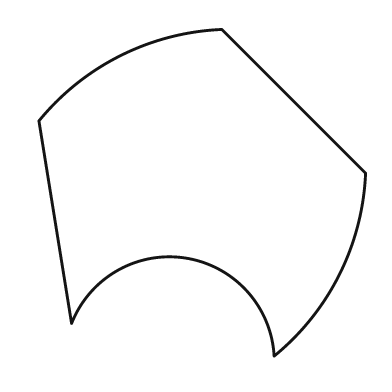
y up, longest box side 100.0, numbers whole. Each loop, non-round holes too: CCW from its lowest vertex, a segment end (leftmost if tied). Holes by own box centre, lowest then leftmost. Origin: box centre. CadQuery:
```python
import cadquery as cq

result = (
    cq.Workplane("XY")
    .moveTo(22.0, -50.0)
    .threePointArc((42.0, -25.0), (50.0, 6.0))
    .lineTo(6.0, 50.0)
    .threePointArc((-25.0, 42.0), (-50.0, 22.0))
    .lineTo(-40.0, -40.0)
    .threePointArc((-5.0, -20.0), (22.0, -50.0))
    .close()
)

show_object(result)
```